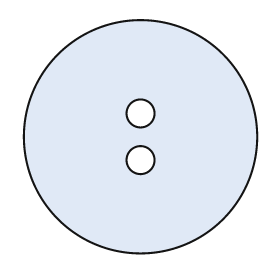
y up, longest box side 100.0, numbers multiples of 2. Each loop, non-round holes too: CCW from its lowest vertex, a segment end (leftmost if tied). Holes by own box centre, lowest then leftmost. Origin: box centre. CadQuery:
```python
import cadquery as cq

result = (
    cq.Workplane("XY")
    .moveTo(0.0, 0.0)
    .circle(50.0)
    .moveTo(0.0, -10.0)
    .circle(6.0)
    .moveTo(0.0, 10.0)
    .circle(6.0)
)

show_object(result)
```